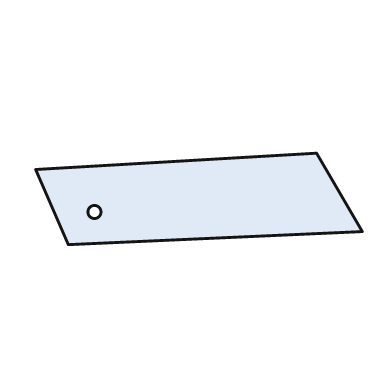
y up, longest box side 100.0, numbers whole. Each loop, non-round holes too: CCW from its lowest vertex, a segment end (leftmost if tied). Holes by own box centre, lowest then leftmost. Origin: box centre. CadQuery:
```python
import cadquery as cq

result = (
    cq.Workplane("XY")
    .moveTo(-40.0, -14.0)
    .lineTo(50.0, -10.0)
    .lineTo(36.0, 14.0)
    .lineTo(-50.0, 9.0)
    .close()
    .moveTo(-32.0, -4.0)
    .circle(2.0)
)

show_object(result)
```